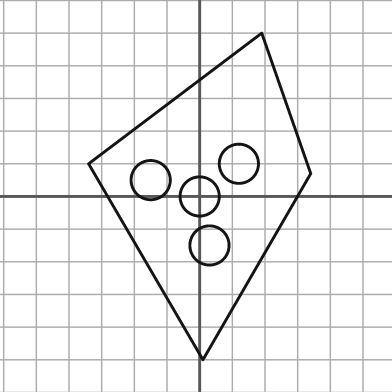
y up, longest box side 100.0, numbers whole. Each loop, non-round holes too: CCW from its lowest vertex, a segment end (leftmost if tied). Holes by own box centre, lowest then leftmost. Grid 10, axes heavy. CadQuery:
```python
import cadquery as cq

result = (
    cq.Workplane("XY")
    .moveTo(1.0, -50.0)
    .lineTo(34.0, 7.0)
    .lineTo(19.0, 50.0)
    .lineTo(-34.0, 10.0)
    .close()
    .moveTo(3.0, -15.0)
    .circle(6.0)
    .moveTo(0.0, 0.0)
    .circle(6.0)
    .moveTo(-15.0, 5.0)
    .circle(6.0)
    .moveTo(12.0, 10.0)
    .circle(6.0)
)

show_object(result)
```